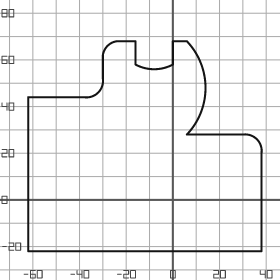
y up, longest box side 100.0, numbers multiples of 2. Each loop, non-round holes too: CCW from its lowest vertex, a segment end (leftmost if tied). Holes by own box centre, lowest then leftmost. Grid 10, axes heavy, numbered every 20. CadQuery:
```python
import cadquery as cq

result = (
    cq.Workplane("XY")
    .moveTo(-62.0, -22.0)
    .lineTo(38.0, -22.0)
    .lineTo(38.0, 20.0)
    .threePointArc((36.0, 26.0), (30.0, 28.0))
    .lineTo(6.0, 28.0)
    .threePointArc((14.0, 48.0), (6.0, 68.0))
    .lineTo(0.0, 68.0)
    .lineTo(0.0, 58.0)
    .threePointArc((-8.0, 56.0), (-16.0, 58.0))
    .lineTo(-16.0, 68.0)
    .lineTo(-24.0, 68.0)
    .threePointArc((-28.0, 66.0), (-30.0, 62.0))
    .lineTo(-30.0, 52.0)
    .threePointArc((-32.0, 46.0), (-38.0, 44.0))
    .lineTo(-62.0, 44.0)
    .close()
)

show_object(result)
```